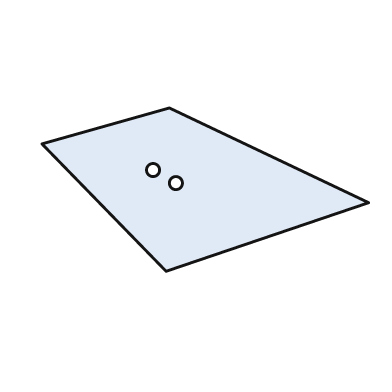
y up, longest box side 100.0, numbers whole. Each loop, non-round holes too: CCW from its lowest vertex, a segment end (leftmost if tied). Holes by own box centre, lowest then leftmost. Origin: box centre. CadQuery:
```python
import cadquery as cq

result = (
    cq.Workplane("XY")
    .moveTo(-12.0, -25.0)
    .lineTo(50.0, -4.0)
    .lineTo(-11.0, 25.0)
    .lineTo(-50.0, 14.0)
    .close()
    .moveTo(-9.0, 2.0)
    .circle(2.0)
    .moveTo(-16.0, 6.0)
    .circle(2.0)
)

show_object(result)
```